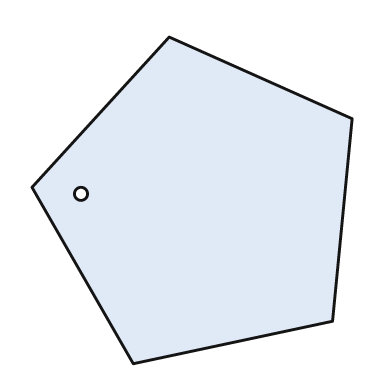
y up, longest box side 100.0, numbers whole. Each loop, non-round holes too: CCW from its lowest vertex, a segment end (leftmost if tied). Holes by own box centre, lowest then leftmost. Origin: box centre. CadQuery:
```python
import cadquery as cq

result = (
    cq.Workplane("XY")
    .moveTo(-18.0, -50.0)
    .lineTo(43.0, -37.0)
    .lineTo(49.0, 25.0)
    .lineTo(-7.0, 50.0)
    .lineTo(-49.0, 4.0)
    .close()
    .moveTo(-34.0, 2.0)
    .circle(2.0)
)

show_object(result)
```